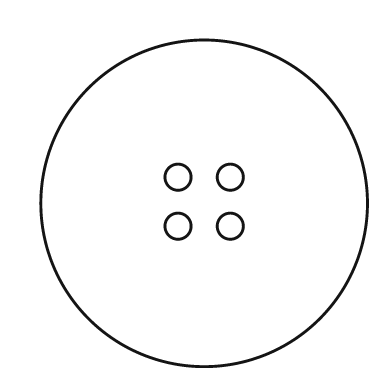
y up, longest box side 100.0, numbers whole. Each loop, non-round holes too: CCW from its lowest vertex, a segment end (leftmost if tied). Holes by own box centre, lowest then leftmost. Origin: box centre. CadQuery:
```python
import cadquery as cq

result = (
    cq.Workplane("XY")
    .moveTo(0.0, 0.0)
    .circle(50.0)
    .moveTo(-8.0, -7.0)
    .circle(4.0)
    .moveTo(8.0, -7.0)
    .circle(4.0)
    .moveTo(-8.0, 8.0)
    .circle(4.0)
    .moveTo(8.0, 8.0)
    .circle(4.0)
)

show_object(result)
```